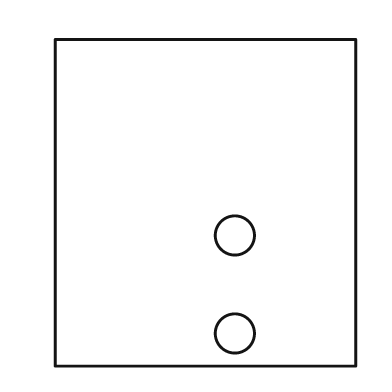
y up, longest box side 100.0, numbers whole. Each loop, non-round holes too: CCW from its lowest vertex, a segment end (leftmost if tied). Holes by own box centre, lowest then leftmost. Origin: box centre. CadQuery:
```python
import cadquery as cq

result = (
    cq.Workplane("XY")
    .moveTo(-46.0, -50.0)
    .lineTo(46.0, -50.0)
    .lineTo(46.0, 50.0)
    .lineTo(-46.0, 50.0)
    .close()
    .moveTo(9.0, -40.0)
    .circle(6.0)
    .moveTo(9.0, -10.0)
    .circle(6.0)
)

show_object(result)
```